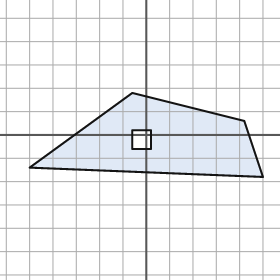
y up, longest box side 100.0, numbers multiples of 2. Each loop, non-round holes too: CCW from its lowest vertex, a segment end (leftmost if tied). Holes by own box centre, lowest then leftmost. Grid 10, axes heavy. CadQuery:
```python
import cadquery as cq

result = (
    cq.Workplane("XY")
    .moveTo(50.0, -18.0)
    .lineTo(42.0, 6.0)
    .lineTo(-6.0, 18.0)
    .lineTo(-50.0, -14.0)
    .close()
    .moveTo(-6.0, -6.0)
    .lineTo(2.0, -6.0)
    .lineTo(2.0, 2.0)
    .lineTo(-6.0, 2.0)
    .close()
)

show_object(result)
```